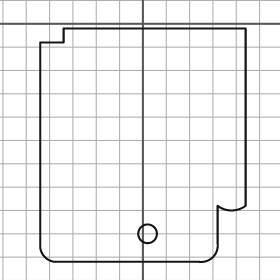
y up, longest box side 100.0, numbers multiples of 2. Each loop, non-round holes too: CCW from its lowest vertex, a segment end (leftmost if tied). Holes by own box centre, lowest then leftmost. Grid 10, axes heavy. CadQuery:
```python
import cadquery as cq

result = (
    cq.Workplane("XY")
    .moveTo(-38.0, -102.0)
    .lineTo(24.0, -102.0)
    .threePointArc((30.0, -100.0), (32.0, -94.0))
    .lineTo(32.0, -78.0)
    .threePointArc((38.0, -80.0), (44.0, -78.0))
    .lineTo(44.0, -2.0)
    .lineTo(-34.0, -2.0)
    .lineTo(-34.0, -8.0)
    .lineTo(-44.0, -8.0)
    .lineTo(-44.0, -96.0)
    .threePointArc((-42.0, -100.0), (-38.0, -102.0))
    .close()
    .moveTo(2.0, -90.0)
    .circle(4.0)
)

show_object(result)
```